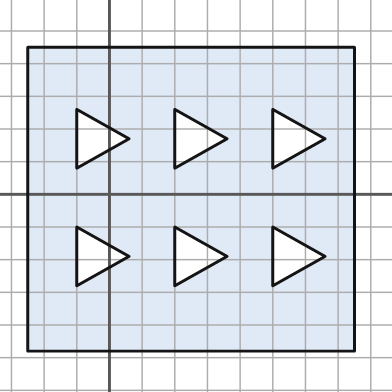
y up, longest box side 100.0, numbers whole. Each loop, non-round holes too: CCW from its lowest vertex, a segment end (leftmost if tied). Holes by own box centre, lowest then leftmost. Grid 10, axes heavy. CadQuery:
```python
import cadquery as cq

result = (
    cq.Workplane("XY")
    .moveTo(-25.0, -48.0)
    .lineTo(75.0, -48.0)
    .lineTo(75.0, 45.0)
    .lineTo(-25.0, 45.0)
    .close()
    .moveTo(-10.0, -28.0)
    .lineTo(6.0, -19.0)
    .lineTo(-10.0, -10.0)
    .close()
    .moveTo(20.0, -28.0)
    .lineTo(36.0, -19.0)
    .lineTo(20.0, -10.0)
    .close()
    .moveTo(50.0, -28.0)
    .lineTo(66.0, -19.0)
    .lineTo(50.0, -10.0)
    .close()
    .moveTo(-10.0, 8.0)
    .lineTo(6.0, 17.0)
    .lineTo(-10.0, 26.0)
    .close()
    .moveTo(20.0, 8.0)
    .lineTo(36.0, 17.0)
    .lineTo(20.0, 26.0)
    .close()
    .moveTo(50.0, 8.0)
    .lineTo(66.0, 17.0)
    .lineTo(50.0, 26.0)
    .close()
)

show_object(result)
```